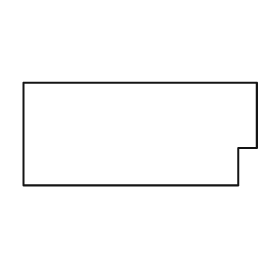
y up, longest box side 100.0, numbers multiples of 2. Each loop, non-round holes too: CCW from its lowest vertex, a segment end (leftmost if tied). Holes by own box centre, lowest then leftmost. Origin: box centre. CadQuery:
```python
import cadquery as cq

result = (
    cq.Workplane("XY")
    .moveTo(-50.0, -22.0)
    .lineTo(42.0, -22.0)
    .lineTo(42.0, -6.0)
    .lineTo(50.0, -6.0)
    .lineTo(50.0, 22.0)
    .lineTo(-50.0, 22.0)
    .close()
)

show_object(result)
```